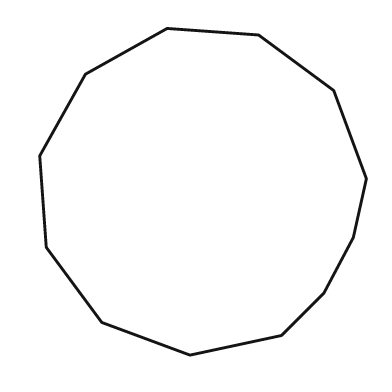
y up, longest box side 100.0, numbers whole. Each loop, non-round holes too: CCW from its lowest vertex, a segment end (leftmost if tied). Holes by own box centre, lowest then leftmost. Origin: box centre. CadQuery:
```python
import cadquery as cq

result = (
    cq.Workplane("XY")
    .moveTo(-4.0, -50.0)
    .lineTo(24.0, -44.0)
    .lineTo(37.0, -31.0)
    .lineTo(46.0, -14.0)
    .lineTo(50.0, 4.0)
    .lineTo(40.0, 31.0)
    .lineTo(17.0, 48.0)
    .lineTo(-11.0, 50.0)
    .lineTo(-36.0, 36.0)
    .lineTo(-50.0, 11.0)
    .lineTo(-48.0, -17.0)
    .lineTo(-31.0, -40.0)
    .close()
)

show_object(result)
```